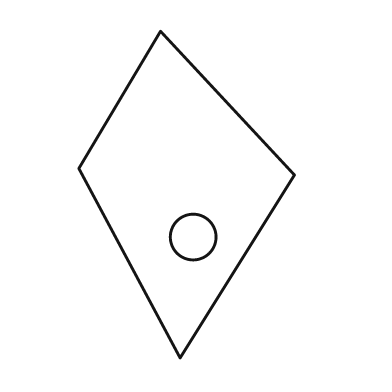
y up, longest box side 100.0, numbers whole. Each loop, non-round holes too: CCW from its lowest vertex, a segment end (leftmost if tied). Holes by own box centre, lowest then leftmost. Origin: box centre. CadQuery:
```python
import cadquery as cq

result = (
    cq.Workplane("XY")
    .moveTo(-2.0, -50.0)
    .lineTo(33.0, 6.0)
    .lineTo(-8.0, 50.0)
    .lineTo(-33.0, 8.0)
    .close()
    .moveTo(2.0, -13.0)
    .circle(7.0)
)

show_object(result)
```